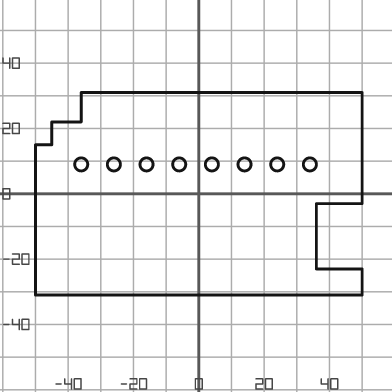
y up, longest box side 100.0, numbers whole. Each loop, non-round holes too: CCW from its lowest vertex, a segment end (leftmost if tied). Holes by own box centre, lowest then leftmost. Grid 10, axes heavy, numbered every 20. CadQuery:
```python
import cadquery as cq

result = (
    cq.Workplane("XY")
    .moveTo(-50.0, -31.0)
    .lineTo(50.0, -31.0)
    .lineTo(50.0, -23.0)
    .lineTo(36.0, -23.0)
    .lineTo(36.0, -3.0)
    .lineTo(50.0, -3.0)
    .lineTo(50.0, 31.0)
    .lineTo(-36.0, 31.0)
    .lineTo(-36.0, 22.0)
    .lineTo(-45.0, 22.0)
    .lineTo(-45.0, 15.0)
    .lineTo(-50.0, 15.0)
    .close()
    .moveTo(-36.0, 9.0)
    .circle(2.0)
    .moveTo(-26.0, 9.0)
    .circle(2.0)
    .moveTo(-16.0, 9.0)
    .circle(2.0)
    .moveTo(-6.0, 9.0)
    .circle(2.0)
    .moveTo(4.0, 9.0)
    .circle(2.0)
    .moveTo(14.0, 9.0)
    .circle(2.0)
    .moveTo(24.0, 9.0)
    .circle(2.0)
    .moveTo(34.0, 9.0)
    .circle(2.0)
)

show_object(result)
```